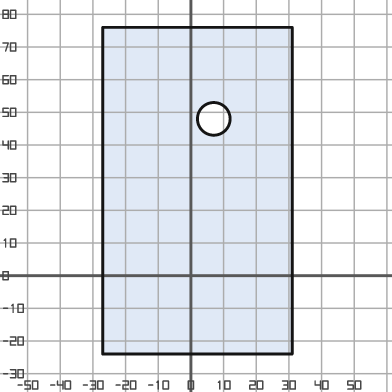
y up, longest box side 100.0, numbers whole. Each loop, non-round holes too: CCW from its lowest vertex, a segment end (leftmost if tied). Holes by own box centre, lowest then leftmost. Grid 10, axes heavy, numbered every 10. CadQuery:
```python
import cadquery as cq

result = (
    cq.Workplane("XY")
    .moveTo(-27.0, -24.0)
    .lineTo(31.0, -24.0)
    .lineTo(31.0, 76.0)
    .lineTo(-27.0, 76.0)
    .close()
    .moveTo(7.0, 48.0)
    .circle(5.0)
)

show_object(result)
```